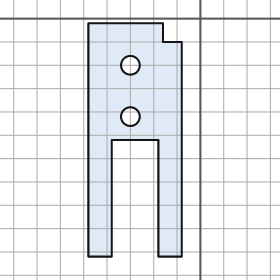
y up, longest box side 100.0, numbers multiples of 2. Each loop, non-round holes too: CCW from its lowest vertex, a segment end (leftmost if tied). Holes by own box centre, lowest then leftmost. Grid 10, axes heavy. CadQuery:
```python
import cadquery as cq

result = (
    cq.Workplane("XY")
    .moveTo(-48.0, -102.0)
    .lineTo(-38.0, -102.0)
    .lineTo(-38.0, -52.0)
    .lineTo(-18.0, -52.0)
    .lineTo(-18.0, -102.0)
    .lineTo(-8.0, -102.0)
    .lineTo(-8.0, -10.0)
    .lineTo(-16.0, -10.0)
    .lineTo(-16.0, -2.0)
    .lineTo(-48.0, -2.0)
    .close()
    .moveTo(-30.0, -42.0)
    .circle(4.0)
    .moveTo(-30.0, -20.0)
    .circle(4.0)
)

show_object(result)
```